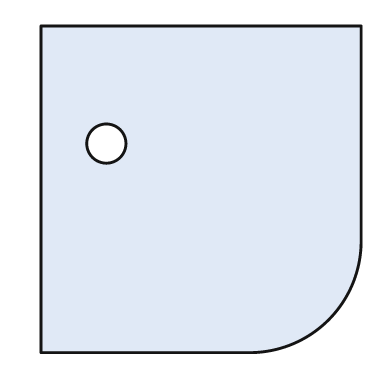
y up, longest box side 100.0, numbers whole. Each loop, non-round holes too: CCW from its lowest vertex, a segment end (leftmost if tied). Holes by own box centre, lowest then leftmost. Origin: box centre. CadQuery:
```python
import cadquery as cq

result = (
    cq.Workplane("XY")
    .moveTo(-49.0, -50.0)
    .lineTo(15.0, -50.0)
    .threePointArc((39.0, -40.0), (49.0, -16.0))
    .lineTo(49.0, 50.0)
    .lineTo(-49.0, 50.0)
    .close()
    .moveTo(-29.0, 14.0)
    .circle(6.0)
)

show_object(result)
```